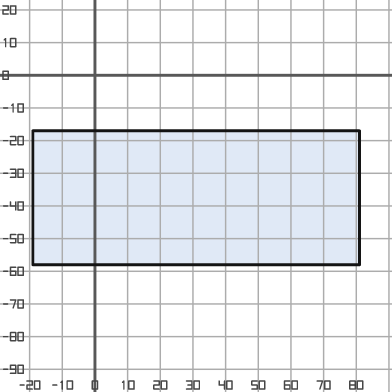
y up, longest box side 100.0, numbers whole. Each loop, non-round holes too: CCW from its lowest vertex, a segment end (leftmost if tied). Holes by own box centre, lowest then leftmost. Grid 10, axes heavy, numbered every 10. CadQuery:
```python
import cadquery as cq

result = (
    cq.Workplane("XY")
    .moveTo(-19.0, -58.0)
    .lineTo(81.0, -58.0)
    .lineTo(81.0, -17.0)
    .lineTo(-19.0, -17.0)
    .close()
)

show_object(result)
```